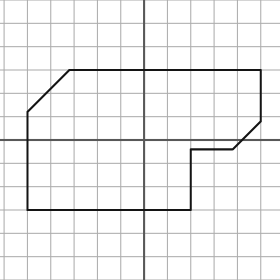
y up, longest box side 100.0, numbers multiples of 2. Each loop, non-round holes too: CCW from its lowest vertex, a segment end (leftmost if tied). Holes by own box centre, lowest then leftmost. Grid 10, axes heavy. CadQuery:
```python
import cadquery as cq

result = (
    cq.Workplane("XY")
    .moveTo(-50.0, -30.0)
    .lineTo(20.0, -30.0)
    .lineTo(20.0, -4.0)
    .lineTo(38.0, -4.0)
    .lineTo(50.0, 8.0)
    .lineTo(50.0, 30.0)
    .lineTo(-32.0, 30.0)
    .lineTo(-50.0, 12.0)
    .close()
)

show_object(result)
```